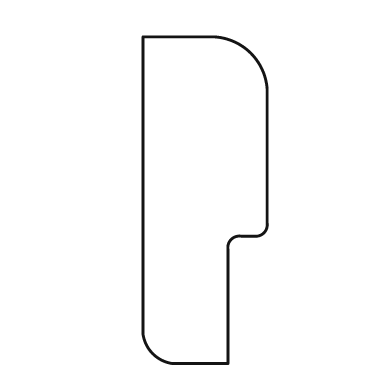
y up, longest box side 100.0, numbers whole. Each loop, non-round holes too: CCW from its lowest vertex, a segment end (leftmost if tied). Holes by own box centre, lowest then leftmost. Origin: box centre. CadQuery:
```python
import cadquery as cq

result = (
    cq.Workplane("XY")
    .moveTo(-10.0, -50.0)
    .lineTo(7.0, -50.0)
    .lineTo(7.0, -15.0)
    .threePointArc((8.0, -12.0), (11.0, -11.0))
    .lineTo(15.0, -11.0)
    .threePointArc((18.0, -10.0), (19.0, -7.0))
    .lineTo(19.0, 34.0)
    .threePointArc((14.0, 45.0), (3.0, 50.0))
    .lineTo(-19.0, 50.0)
    .lineTo(-19.0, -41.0)
    .threePointArc((-16.0, -47.0), (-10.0, -50.0))
    .close()
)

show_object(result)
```